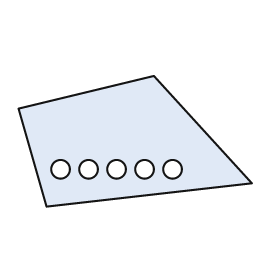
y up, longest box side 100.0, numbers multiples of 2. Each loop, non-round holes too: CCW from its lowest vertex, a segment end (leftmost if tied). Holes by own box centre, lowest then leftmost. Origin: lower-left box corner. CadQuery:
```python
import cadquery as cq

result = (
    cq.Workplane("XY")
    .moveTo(12.0, 0.0)
    .lineTo(100.0, 10.0)
    .lineTo(58.0, 56.0)
    .lineTo(0.0, 42.0)
    .close()
    .moveTo(18.0, 16.0)
    .circle(4.0)
    .moveTo(30.0, 16.0)
    .circle(4.0)
    .moveTo(42.0, 16.0)
    .circle(4.0)
    .moveTo(54.0, 16.0)
    .circle(4.0)
    .moveTo(66.0, 16.0)
    .circle(4.0)
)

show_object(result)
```